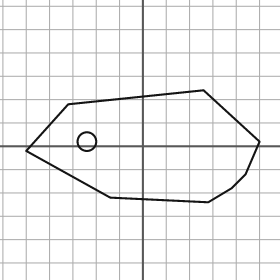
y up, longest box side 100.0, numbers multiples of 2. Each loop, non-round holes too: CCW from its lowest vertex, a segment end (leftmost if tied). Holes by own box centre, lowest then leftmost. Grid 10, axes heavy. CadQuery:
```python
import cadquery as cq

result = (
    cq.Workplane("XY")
    .moveTo(28.0, -24.0)
    .lineTo(38.0, -18.0)
    .lineTo(44.0, -12.0)
    .lineTo(50.0, 2.0)
    .lineTo(26.0, 24.0)
    .lineTo(-32.0, 18.0)
    .lineTo(-50.0, -2.0)
    .lineTo(-14.0, -22.0)
    .close()
    .moveTo(-24.0, 2.0)
    .circle(4.0)
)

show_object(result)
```